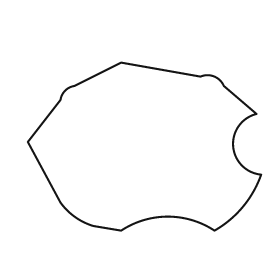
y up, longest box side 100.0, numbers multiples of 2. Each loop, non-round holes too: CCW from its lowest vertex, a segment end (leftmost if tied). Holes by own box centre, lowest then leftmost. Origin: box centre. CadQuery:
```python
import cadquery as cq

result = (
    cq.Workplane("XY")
    .moveTo(-10.0, -36.0)
    .threePointArc((10.0, -30.0), (30.0, -36.0))
    .threePointArc((42.0, -26.0), (50.0, -12.0))
    .threePointArc((38.0, 0.0), (48.0, 14.0))
    .lineTo(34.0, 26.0)
    .threePointArc((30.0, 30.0), (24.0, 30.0))
    .lineTo(-10.0, 36.0)
    .lineTo(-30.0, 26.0)
    .threePointArc((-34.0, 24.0), (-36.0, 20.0))
    .lineTo(-50.0, 2.0)
    .lineTo(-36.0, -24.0)
    .threePointArc((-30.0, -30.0), (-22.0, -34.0))
    .close()
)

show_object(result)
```